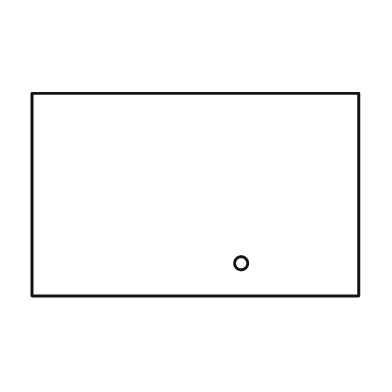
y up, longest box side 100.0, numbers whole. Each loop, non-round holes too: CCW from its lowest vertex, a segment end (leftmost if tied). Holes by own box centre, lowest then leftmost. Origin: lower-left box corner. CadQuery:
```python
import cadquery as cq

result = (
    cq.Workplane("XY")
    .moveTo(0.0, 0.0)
    .lineTo(100.0, 0.0)
    .lineTo(100.0, 62.0)
    .lineTo(0.0, 62.0)
    .close()
    .moveTo(64.0, 10.0)
    .circle(2.0)
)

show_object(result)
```